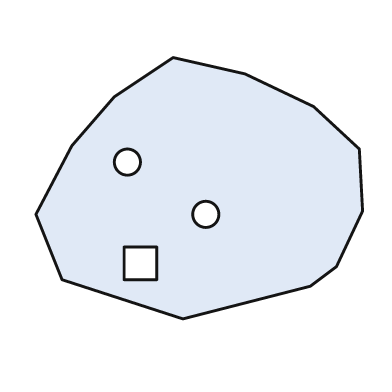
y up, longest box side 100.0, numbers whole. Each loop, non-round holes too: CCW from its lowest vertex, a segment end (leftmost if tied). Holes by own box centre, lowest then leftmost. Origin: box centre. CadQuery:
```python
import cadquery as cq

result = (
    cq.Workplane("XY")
    .moveTo(-5.0, -40.0)
    .lineTo(34.0, -30.0)
    .lineTo(42.0, -24.0)
    .lineTo(50.0, -7.0)
    .lineTo(49.0, 12.0)
    .lineTo(35.0, 25.0)
    .lineTo(14.0, 35.0)
    .lineTo(-8.0, 40.0)
    .lineTo(-26.0, 28.0)
    .lineTo(-39.0, 13.0)
    .lineTo(-50.0, -8.0)
    .lineTo(-42.0, -28.0)
    .close()
    .moveTo(-23.0, -28.0)
    .lineTo(-13.0, -28.0)
    .lineTo(-13.0, -18.0)
    .lineTo(-23.0, -18.0)
    .close()
    .moveTo(2.0, -8.0)
    .circle(4.0)
    .moveTo(-22.0, 8.0)
    .circle(4.0)
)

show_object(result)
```